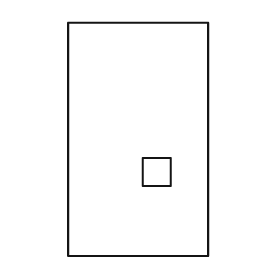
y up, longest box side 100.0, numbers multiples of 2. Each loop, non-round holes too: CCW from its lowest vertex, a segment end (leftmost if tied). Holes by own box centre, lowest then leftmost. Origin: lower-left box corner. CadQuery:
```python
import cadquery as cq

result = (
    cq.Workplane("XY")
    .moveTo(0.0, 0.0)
    .lineTo(60.0, 0.0)
    .lineTo(60.0, 100.0)
    .lineTo(0.0, 100.0)
    .close()
    .moveTo(32.0, 30.0)
    .lineTo(44.0, 30.0)
    .lineTo(44.0, 42.0)
    .lineTo(32.0, 42.0)
    .close()
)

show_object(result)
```